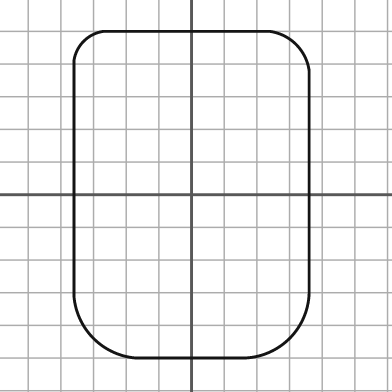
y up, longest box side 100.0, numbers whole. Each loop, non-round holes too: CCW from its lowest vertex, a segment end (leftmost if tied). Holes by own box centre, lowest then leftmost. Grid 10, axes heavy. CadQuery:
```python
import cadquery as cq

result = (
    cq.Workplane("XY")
    .moveTo(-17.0, -50.0)
    .lineTo(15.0, -50.0)
    .threePointArc((30.0, -44.0), (36.0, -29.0))
    .lineTo(36.0, 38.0)
    .threePointArc((32.0, 46.0), (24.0, 50.0))
    .lineTo(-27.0, 50.0)
    .threePointArc((-33.0, 47.0), (-36.0, 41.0))
    .lineTo(-36.0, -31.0)
    .threePointArc((-30.0, -44.0), (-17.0, -50.0))
    .close()
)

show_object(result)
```